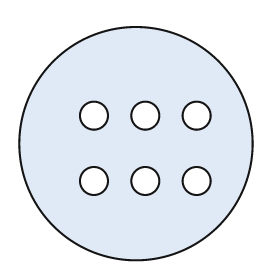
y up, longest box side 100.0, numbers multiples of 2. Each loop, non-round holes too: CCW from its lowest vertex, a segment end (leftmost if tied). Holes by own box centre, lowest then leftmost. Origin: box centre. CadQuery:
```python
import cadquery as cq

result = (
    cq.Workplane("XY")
    .moveTo(0.0, 0.0)
    .circle(50.0)
    .moveTo(-18.0, -16.0)
    .circle(6.0)
    .moveTo(4.0, -16.0)
    .circle(6.0)
    .moveTo(26.0, -16.0)
    .circle(6.0)
    .moveTo(-18.0, 12.0)
    .circle(6.0)
    .moveTo(4.0, 12.0)
    .circle(6.0)
    .moveTo(26.0, 12.0)
    .circle(6.0)
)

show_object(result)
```